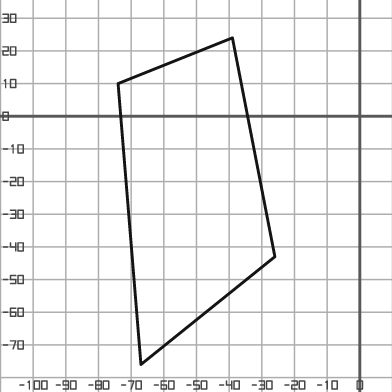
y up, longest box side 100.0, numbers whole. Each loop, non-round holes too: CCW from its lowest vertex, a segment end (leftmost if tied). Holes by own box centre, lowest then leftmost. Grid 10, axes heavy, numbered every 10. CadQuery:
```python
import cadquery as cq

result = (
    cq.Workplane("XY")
    .moveTo(-67.0, -76.0)
    .lineTo(-26.0, -43.0)
    .lineTo(-39.0, 24.0)
    .lineTo(-74.0, 10.0)
    .close()
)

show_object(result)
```